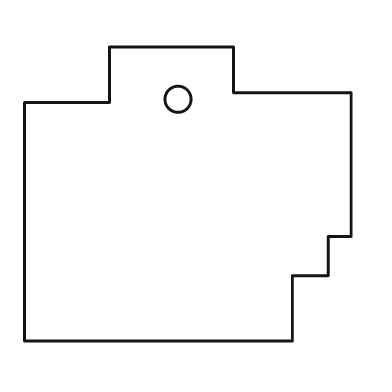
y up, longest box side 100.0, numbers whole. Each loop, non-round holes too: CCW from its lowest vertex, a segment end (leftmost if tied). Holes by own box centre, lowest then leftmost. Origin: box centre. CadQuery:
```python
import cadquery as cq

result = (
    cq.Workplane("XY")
    .moveTo(-50.0, -45.0)
    .lineTo(32.0, -45.0)
    .lineTo(32.0, -25.0)
    .lineTo(43.0, -25.0)
    .lineTo(43.0, -13.0)
    .lineTo(50.0, -13.0)
    .lineTo(50.0, 31.0)
    .lineTo(14.0, 31.0)
    .lineTo(14.0, 45.0)
    .lineTo(-24.0, 45.0)
    .lineTo(-24.0, 28.0)
    .lineTo(-50.0, 28.0)
    .close()
    .moveTo(-3.0, 29.0)
    .circle(4.0)
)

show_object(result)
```